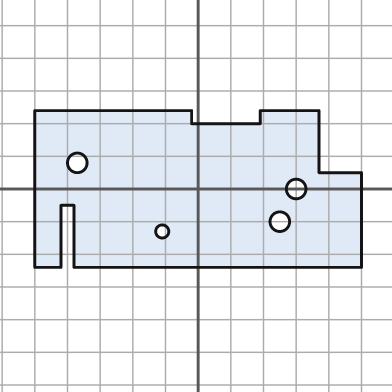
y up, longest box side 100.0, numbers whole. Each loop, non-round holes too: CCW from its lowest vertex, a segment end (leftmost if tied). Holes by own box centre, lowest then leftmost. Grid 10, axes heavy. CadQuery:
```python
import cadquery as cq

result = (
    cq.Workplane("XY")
    .moveTo(-50.0, -24.0)
    .lineTo(-42.0, -24.0)
    .lineTo(-42.0, -5.0)
    .lineTo(-38.0, -5.0)
    .lineTo(-38.0, -24.0)
    .lineTo(50.0, -24.0)
    .lineTo(50.0, 5.0)
    .lineTo(37.0, 5.0)
    .lineTo(37.0, 24.0)
    .lineTo(19.0, 24.0)
    .lineTo(19.0, 20.0)
    .lineTo(-2.0, 20.0)
    .lineTo(-2.0, 24.0)
    .lineTo(-50.0, 24.0)
    .close()
    .moveTo(-11.0, -13.0)
    .circle(2.0)
    .moveTo(25.0, -10.0)
    .circle(3.0)
    .moveTo(30.0, 0.0)
    .circle(3.0)
    .moveTo(-37.0, 8.0)
    .circle(3.0)
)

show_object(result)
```